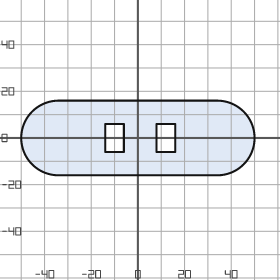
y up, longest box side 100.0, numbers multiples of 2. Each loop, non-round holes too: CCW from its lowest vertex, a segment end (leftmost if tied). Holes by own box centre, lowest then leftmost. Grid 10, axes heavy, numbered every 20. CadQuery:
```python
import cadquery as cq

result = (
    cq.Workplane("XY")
    .moveTo(-34.0, -16.0)
    .lineTo(34.0, -16.0)
    .threePointArc((50.0, 0.0), (34.0, 16.0))
    .lineTo(-34.0, 16.0)
    .threePointArc((-50.0, 0.0), (-34.0, -16.0))
    .close()
    .moveTo(-14.0, -6.0)
    .lineTo(-6.0, -6.0)
    .lineTo(-6.0, 6.0)
    .lineTo(-14.0, 6.0)
    .close()
    .moveTo(8.0, -6.0)
    .lineTo(16.0, -6.0)
    .lineTo(16.0, 6.0)
    .lineTo(8.0, 6.0)
    .close()
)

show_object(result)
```